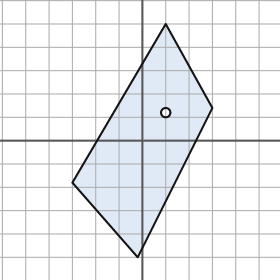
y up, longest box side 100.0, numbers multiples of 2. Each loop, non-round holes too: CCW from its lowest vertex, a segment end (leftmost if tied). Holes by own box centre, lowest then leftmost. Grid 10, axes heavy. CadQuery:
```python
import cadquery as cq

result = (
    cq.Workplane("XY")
    .moveTo(-2.0, -50.0)
    .lineTo(30.0, 14.0)
    .lineTo(10.0, 50.0)
    .lineTo(-30.0, -18.0)
    .close()
    .moveTo(10.0, 12.0)
    .circle(2.0)
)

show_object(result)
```